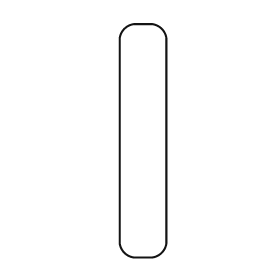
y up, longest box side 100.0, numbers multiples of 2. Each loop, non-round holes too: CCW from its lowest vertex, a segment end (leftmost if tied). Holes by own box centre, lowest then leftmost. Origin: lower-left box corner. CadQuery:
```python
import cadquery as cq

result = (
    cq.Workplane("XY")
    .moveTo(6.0, 0.0)
    .lineTo(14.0, 0.0)
    .threePointArc((18.0, 2.0), (20.0, 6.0))
    .lineTo(20.0, 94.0)
    .threePointArc((18.0, 98.0), (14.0, 100.0))
    .lineTo(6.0, 100.0)
    .threePointArc((2.0, 98.0), (0.0, 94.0))
    .lineTo(0.0, 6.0)
    .threePointArc((2.0, 2.0), (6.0, 0.0))
    .close()
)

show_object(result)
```